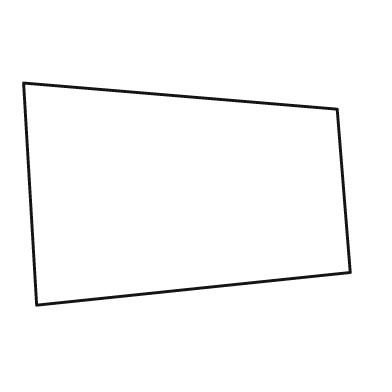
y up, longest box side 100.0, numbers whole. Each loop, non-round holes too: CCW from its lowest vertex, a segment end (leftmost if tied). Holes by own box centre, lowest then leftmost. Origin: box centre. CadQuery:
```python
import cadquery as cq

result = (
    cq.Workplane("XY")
    .moveTo(-46.0, -34.0)
    .lineTo(50.0, -24.0)
    .lineTo(46.0, 26.0)
    .lineTo(-50.0, 34.0)
    .close()
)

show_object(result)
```